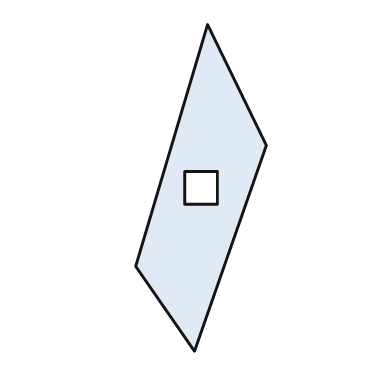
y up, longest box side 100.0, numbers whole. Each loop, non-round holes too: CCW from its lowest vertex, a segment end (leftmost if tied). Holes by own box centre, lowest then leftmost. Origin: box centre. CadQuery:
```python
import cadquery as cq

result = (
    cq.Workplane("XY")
    .moveTo(-2.0, -50.0)
    .lineTo(20.0, 13.0)
    .lineTo(2.0, 50.0)
    .lineTo(-20.0, -24.0)
    .close()
    .moveTo(-5.0, -5.0)
    .lineTo(5.0, -5.0)
    .lineTo(5.0, 5.0)
    .lineTo(-5.0, 5.0)
    .close()
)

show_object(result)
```